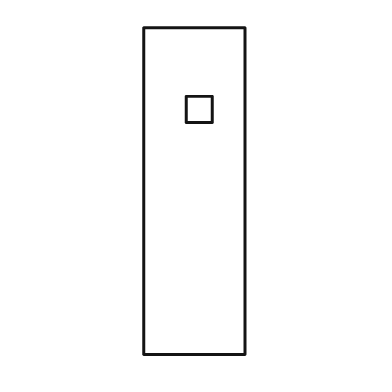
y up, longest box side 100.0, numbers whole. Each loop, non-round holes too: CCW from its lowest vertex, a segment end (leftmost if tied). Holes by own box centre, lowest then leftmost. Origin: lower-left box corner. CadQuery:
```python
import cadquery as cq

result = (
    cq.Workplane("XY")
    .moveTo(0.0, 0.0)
    .lineTo(31.0, 0.0)
    .lineTo(31.0, 100.0)
    .lineTo(0.0, 100.0)
    .close()
    .moveTo(13.0, 71.0)
    .lineTo(21.0, 71.0)
    .lineTo(21.0, 79.0)
    .lineTo(13.0, 79.0)
    .close()
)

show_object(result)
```